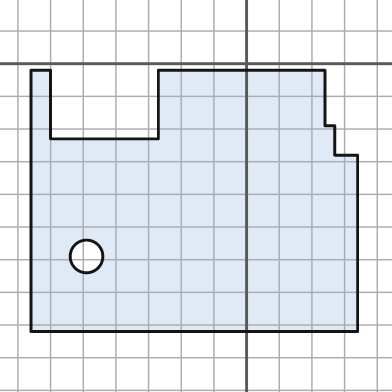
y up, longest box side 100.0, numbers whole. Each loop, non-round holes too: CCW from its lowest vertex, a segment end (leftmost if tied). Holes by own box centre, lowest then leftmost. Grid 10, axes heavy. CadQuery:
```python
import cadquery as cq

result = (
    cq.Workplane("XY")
    .moveTo(-66.0, -82.0)
    .lineTo(34.0, -82.0)
    .lineTo(34.0, -28.0)
    .lineTo(27.0, -28.0)
    .lineTo(27.0, -19.0)
    .lineTo(24.0, -19.0)
    .lineTo(24.0, -2.0)
    .lineTo(-27.0, -2.0)
    .lineTo(-27.0, -23.0)
    .lineTo(-60.0, -23.0)
    .lineTo(-60.0, -2.0)
    .lineTo(-66.0, -2.0)
    .close()
    .moveTo(-49.0, -59.0)
    .circle(5.0)
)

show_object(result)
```